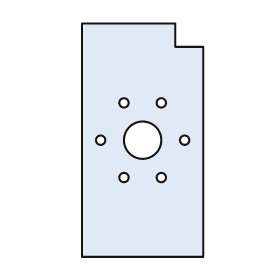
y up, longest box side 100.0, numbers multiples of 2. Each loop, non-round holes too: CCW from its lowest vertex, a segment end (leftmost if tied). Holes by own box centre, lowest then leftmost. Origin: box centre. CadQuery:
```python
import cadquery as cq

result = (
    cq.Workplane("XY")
    .moveTo(-26.0, -50.0)
    .lineTo(26.0, -50.0)
    .lineTo(26.0, 40.0)
    .lineTo(14.0, 40.0)
    .lineTo(14.0, 50.0)
    .lineTo(-26.0, 50.0)
    .close()
    .moveTo(-8.0, -16.0)
    .circle(2.0)
    .moveTo(8.0, -16.0)
    .circle(2.0)
    .moveTo(-18.0, 0.0)
    .circle(2.0)
    .moveTo(0.0, 0.0)
    .circle(8.0)
    .moveTo(18.0, 0.0)
    .circle(2.0)
    .moveTo(-8.0, 16.0)
    .circle(2.0)
    .moveTo(8.0, 16.0)
    .circle(2.0)
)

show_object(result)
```